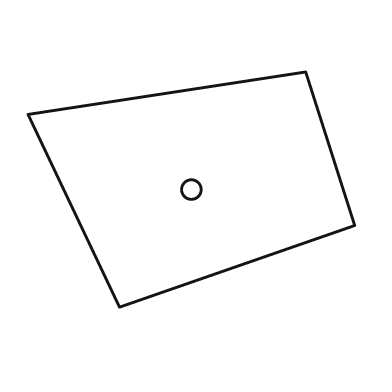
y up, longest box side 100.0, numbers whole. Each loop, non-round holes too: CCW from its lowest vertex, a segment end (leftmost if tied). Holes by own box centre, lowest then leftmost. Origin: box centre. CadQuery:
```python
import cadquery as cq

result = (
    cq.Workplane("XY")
    .moveTo(-22.0, -36.0)
    .lineTo(50.0, -11.0)
    .lineTo(35.0, 36.0)
    .lineTo(-50.0, 23.0)
    .close()
    .moveTo(0.0, 0.0)
    .circle(3.0)
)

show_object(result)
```